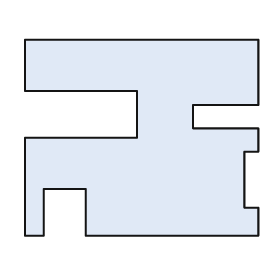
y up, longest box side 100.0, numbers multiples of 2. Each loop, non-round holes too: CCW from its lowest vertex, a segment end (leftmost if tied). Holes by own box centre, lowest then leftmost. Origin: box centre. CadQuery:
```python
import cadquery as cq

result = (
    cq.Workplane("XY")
    .moveTo(-50.0, -42.0)
    .lineTo(-42.0, -42.0)
    .lineTo(-42.0, -22.0)
    .lineTo(-24.0, -22.0)
    .lineTo(-24.0, -42.0)
    .lineTo(50.0, -42.0)
    .lineTo(50.0, -30.0)
    .lineTo(44.0, -30.0)
    .lineTo(44.0, -6.0)
    .lineTo(50.0, -6.0)
    .lineTo(50.0, 4.0)
    .lineTo(22.0, 4.0)
    .lineTo(22.0, 14.0)
    .lineTo(50.0, 14.0)
    .lineTo(50.0, 42.0)
    .lineTo(-50.0, 42.0)
    .lineTo(-50.0, 20.0)
    .lineTo(-2.0, 20.0)
    .lineTo(-2.0, 0.0)
    .lineTo(-50.0, 0.0)
    .close()
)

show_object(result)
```